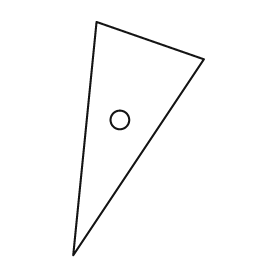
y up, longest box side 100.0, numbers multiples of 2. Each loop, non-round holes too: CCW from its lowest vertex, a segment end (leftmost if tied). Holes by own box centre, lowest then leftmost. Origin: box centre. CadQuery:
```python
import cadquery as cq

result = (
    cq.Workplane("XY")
    .moveTo(-28.0, -50.0)
    .lineTo(28.0, 34.0)
    .lineTo(-18.0, 50.0)
    .close()
    .moveTo(-8.0, 8.0)
    .circle(4.0)
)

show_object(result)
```